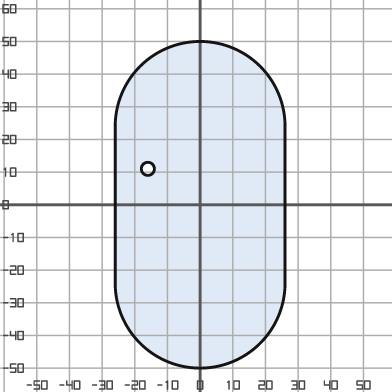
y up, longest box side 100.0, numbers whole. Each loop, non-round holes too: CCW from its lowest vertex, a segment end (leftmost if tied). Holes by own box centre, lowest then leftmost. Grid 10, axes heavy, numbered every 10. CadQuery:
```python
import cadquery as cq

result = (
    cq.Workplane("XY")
    .moveTo(-26.0, -24.0)
    .threePointArc((0.0, -50.0), (26.0, -24.0))
    .lineTo(26.0, 24.0)
    .threePointArc((0.0, 50.0), (-26.0, 24.0))
    .close()
    .moveTo(-16.0, 11.0)
    .circle(2.0)
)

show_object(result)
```